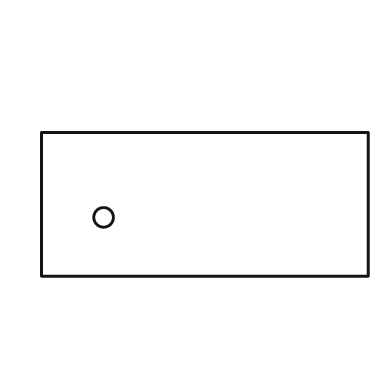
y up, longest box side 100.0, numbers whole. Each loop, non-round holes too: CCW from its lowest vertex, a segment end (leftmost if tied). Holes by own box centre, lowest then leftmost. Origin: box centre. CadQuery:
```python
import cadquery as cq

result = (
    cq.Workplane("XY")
    .moveTo(-50.0, -22.0)
    .lineTo(50.0, -22.0)
    .lineTo(50.0, 22.0)
    .lineTo(-50.0, 22.0)
    .close()
    .moveTo(-31.0, -4.0)
    .circle(3.0)
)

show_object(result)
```